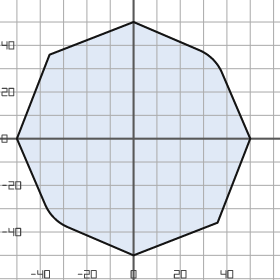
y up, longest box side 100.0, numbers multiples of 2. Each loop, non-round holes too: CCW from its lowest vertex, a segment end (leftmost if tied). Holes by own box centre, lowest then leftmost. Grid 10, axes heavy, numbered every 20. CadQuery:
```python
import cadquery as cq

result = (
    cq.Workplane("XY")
    .moveTo(0.0, -50.0)
    .lineTo(36.0, -36.0)
    .lineTo(50.0, 0.0)
    .lineTo(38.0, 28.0)
    .threePointArc((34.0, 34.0), (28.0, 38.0))
    .lineTo(0.0, 50.0)
    .lineTo(-36.0, 36.0)
    .lineTo(-50.0, 0.0)
    .lineTo(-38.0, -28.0)
    .threePointArc((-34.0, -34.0), (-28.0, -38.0))
    .close()
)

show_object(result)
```